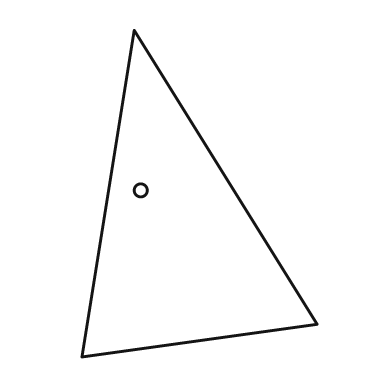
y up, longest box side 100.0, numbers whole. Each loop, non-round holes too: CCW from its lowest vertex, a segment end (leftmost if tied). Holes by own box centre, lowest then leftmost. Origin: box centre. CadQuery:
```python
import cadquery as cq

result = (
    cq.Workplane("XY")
    .moveTo(-36.0, -50.0)
    .lineTo(36.0, -40.0)
    .lineTo(-20.0, 50.0)
    .close()
    .moveTo(-18.0, 1.0)
    .circle(2.0)
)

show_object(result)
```